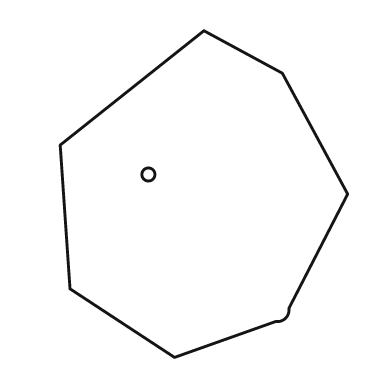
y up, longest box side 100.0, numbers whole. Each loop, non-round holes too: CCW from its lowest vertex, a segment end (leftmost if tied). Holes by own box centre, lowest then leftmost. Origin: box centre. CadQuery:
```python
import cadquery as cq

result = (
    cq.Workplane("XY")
    .moveTo(-9.0, -50.0)
    .lineTo(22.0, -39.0)
    .threePointArc((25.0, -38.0), (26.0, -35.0))
    .lineTo(44.0, 0.0)
    .lineTo(24.0, 37.0)
    .lineTo(0.0, 50.0)
    .lineTo(-44.0, 15.0)
    .lineTo(-41.0, -29.0)
    .close()
    .moveTo(-17.0, 6.0)
    .circle(2.0)
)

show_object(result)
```